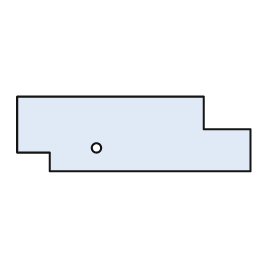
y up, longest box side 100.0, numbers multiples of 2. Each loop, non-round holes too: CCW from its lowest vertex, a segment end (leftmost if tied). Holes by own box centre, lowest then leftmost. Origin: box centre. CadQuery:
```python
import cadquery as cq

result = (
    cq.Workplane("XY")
    .moveTo(-36.0, -16.0)
    .lineTo(50.0, -16.0)
    .lineTo(50.0, 2.0)
    .lineTo(30.0, 2.0)
    .lineTo(30.0, 16.0)
    .lineTo(-50.0, 16.0)
    .lineTo(-50.0, -8.0)
    .lineTo(-36.0, -8.0)
    .close()
    .moveTo(-16.0, -6.0)
    .circle(2.0)
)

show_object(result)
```